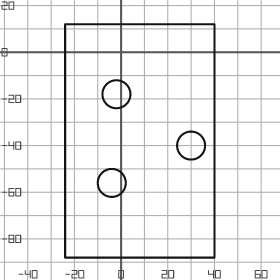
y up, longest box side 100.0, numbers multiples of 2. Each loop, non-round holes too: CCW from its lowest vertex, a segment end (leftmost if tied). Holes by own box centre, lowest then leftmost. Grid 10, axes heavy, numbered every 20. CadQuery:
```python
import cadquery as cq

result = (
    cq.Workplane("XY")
    .moveTo(-24.0, -88.0)
    .lineTo(40.0, -88.0)
    .lineTo(40.0, 12.0)
    .lineTo(-24.0, 12.0)
    .close()
    .moveTo(-4.0, -56.0)
    .circle(6.0)
    .moveTo(30.0, -40.0)
    .circle(6.0)
    .moveTo(-2.0, -18.0)
    .circle(6.0)
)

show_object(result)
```